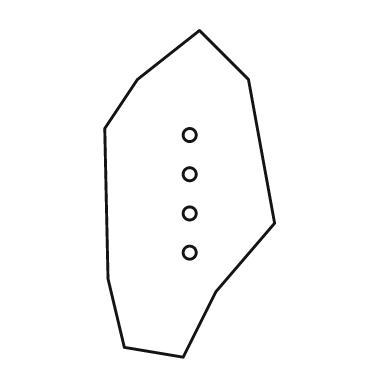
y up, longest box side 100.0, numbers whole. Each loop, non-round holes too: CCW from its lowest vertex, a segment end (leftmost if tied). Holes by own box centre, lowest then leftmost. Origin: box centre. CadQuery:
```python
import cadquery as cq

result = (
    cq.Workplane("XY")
    .moveTo(-2.0, -50.0)
    .lineTo(8.0, -30.0)
    .lineTo(26.0, -9.0)
    .lineTo(18.0, 35.0)
    .lineTo(3.0, 50.0)
    .lineTo(-16.0, 35.0)
    .lineTo(-26.0, 20.0)
    .lineTo(-25.0, -26.0)
    .lineTo(-20.0, -47.0)
    .close()
    .moveTo(0.0, -18.0)
    .circle(2.0)
    .moveTo(0.0, -6.0)
    .circle(2.0)
    .moveTo(0.0, 6.0)
    .circle(2.0)
    .moveTo(0.0, 18.0)
    .circle(2.0)
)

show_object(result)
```